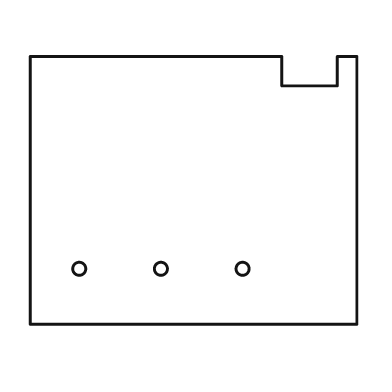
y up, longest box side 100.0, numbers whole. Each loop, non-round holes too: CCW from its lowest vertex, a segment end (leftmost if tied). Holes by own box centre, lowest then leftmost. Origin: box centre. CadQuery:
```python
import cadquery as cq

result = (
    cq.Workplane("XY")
    .moveTo(-50.0, -41.0)
    .lineTo(50.0, -41.0)
    .lineTo(50.0, 41.0)
    .lineTo(44.0, 41.0)
    .lineTo(44.0, 32.0)
    .lineTo(27.0, 32.0)
    .lineTo(27.0, 41.0)
    .lineTo(-50.0, 41.0)
    .close()
    .moveTo(-35.0, -24.0)
    .circle(2.0)
    .moveTo(-10.0, -24.0)
    .circle(2.0)
    .moveTo(15.0, -24.0)
    .circle(2.0)
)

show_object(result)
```